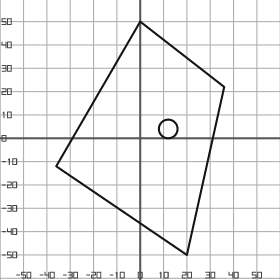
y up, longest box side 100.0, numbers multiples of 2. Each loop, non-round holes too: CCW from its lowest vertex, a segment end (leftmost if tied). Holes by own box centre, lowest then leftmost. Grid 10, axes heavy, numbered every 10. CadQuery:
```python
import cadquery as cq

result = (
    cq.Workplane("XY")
    .moveTo(20.0, -50.0)
    .lineTo(36.0, 22.0)
    .lineTo(0.0, 50.0)
    .lineTo(-36.0, -12.0)
    .close()
    .moveTo(12.0, 4.0)
    .circle(4.0)
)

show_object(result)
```